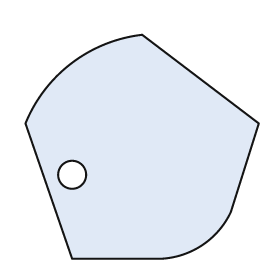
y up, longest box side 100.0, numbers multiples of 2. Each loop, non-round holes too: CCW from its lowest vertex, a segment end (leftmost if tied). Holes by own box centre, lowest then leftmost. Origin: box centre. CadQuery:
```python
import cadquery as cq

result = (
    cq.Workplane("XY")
    .moveTo(-30.0, -48.0)
    .lineTo(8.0, -48.0)
    .threePointArc((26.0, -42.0), (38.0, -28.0))
    .lineTo(50.0, 10.0)
    .lineTo(0.0, 48.0)
    .threePointArc((-30.0, 36.0), (-50.0, 10.0))
    .close()
    .moveTo(-30.0, -12.0)
    .circle(6.0)
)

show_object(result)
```